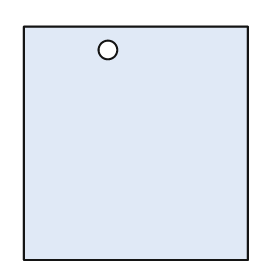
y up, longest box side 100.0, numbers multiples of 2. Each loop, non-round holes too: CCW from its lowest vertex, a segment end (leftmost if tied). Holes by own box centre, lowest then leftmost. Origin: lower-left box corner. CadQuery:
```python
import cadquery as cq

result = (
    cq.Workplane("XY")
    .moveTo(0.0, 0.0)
    .lineTo(96.0, 0.0)
    .lineTo(96.0, 100.0)
    .lineTo(0.0, 100.0)
    .close()
    .moveTo(36.0, 90.0)
    .circle(4.0)
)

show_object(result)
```